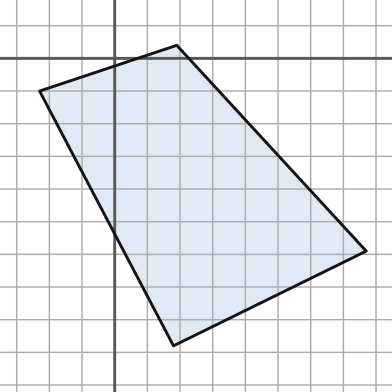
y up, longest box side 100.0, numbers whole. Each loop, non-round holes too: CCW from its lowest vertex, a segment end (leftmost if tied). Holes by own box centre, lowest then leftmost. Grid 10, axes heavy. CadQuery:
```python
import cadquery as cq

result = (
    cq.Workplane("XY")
    .moveTo(18.0, -88.0)
    .lineTo(77.0, -59.0)
    .lineTo(19.0, 4.0)
    .lineTo(-23.0, -10.0)
    .close()
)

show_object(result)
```